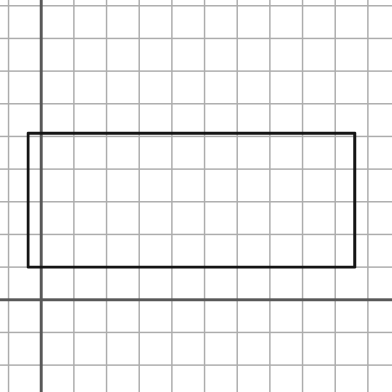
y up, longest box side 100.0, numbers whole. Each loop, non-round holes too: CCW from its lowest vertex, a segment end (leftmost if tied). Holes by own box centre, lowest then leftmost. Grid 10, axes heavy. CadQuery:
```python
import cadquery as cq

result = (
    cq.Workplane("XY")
    .moveTo(-4.0, 10.0)
    .lineTo(96.0, 10.0)
    .lineTo(96.0, 51.0)
    .lineTo(-4.0, 51.0)
    .close()
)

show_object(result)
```